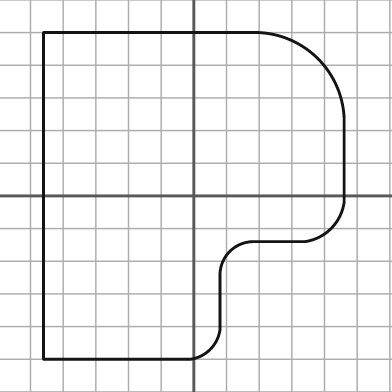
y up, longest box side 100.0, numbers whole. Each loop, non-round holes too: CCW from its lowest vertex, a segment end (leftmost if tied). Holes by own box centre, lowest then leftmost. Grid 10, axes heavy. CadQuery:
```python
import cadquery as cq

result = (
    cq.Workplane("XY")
    .moveTo(-46.0, -50.0)
    .lineTo(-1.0, -50.0)
    .threePointArc((5.0, -47.0), (8.0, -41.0))
    .lineTo(8.0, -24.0)
    .threePointArc((11.0, -17.0), (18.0, -14.0))
    .lineTo(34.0, -14.0)
    .threePointArc((42.0, -10.0), (46.0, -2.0))
    .lineTo(46.0, 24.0)
    .threePointArc((38.0, 42.0), (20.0, 50.0))
    .lineTo(-46.0, 50.0)
    .close()
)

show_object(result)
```